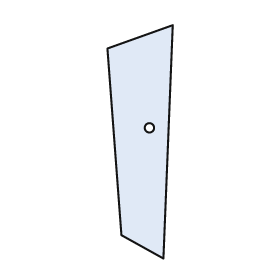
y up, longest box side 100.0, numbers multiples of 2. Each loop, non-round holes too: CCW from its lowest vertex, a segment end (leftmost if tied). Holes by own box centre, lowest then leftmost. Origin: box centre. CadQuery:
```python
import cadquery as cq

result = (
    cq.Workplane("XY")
    .moveTo(10.0, -50.0)
    .lineTo(14.0, 50.0)
    .lineTo(-14.0, 40.0)
    .lineTo(-8.0, -40.0)
    .close()
    .moveTo(4.0, 6.0)
    .circle(2.0)
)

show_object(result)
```